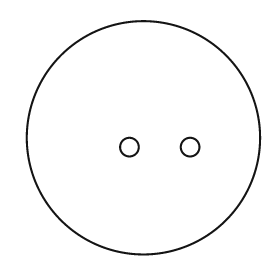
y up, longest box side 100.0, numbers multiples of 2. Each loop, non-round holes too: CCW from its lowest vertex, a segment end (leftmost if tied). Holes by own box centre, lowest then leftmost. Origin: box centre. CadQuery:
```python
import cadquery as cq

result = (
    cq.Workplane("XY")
    .moveTo(0.0, 0.0)
    .circle(50.0)
    .moveTo(-6.0, -4.0)
    .circle(4.0)
    .moveTo(20.0, -4.0)
    .circle(4.0)
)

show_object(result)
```